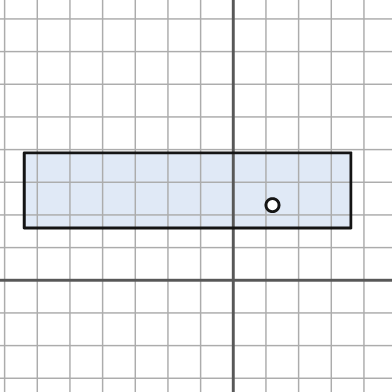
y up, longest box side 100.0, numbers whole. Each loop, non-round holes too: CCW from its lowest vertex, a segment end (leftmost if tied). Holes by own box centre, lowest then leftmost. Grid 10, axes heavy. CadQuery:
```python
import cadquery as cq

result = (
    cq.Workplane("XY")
    .moveTo(-64.0, 16.0)
    .lineTo(36.0, 16.0)
    .lineTo(36.0, 39.0)
    .lineTo(-64.0, 39.0)
    .close()
    .moveTo(12.0, 23.0)
    .circle(2.0)
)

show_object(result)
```